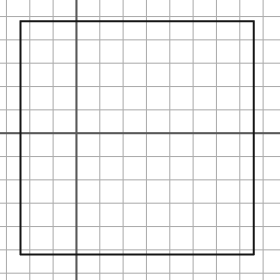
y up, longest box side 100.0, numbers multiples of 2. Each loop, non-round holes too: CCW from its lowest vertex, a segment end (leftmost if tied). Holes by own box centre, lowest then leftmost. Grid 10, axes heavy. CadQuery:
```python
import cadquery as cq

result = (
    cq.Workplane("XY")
    .moveTo(-24.0, -52.0)
    .lineTo(76.0, -52.0)
    .lineTo(76.0, 48.0)
    .lineTo(-24.0, 48.0)
    .close()
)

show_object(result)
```